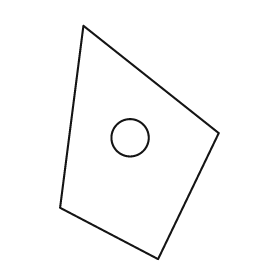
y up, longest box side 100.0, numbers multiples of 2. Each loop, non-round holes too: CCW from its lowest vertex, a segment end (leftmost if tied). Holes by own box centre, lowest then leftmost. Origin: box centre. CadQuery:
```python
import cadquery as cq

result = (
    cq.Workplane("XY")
    .moveTo(8.0, -50.0)
    .lineTo(34.0, 4.0)
    .lineTo(-24.0, 50.0)
    .lineTo(-34.0, -28.0)
    .close()
    .moveTo(-4.0, 2.0)
    .circle(8.0)
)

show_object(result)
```